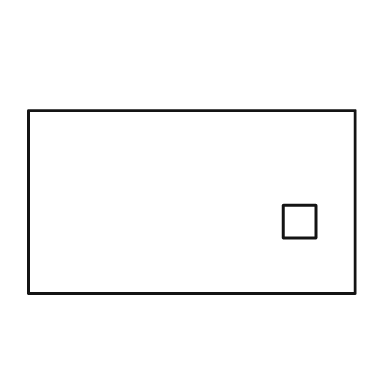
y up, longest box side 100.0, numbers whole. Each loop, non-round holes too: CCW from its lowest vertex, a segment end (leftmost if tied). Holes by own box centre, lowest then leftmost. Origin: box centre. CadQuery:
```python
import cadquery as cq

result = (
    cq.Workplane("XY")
    .moveTo(-50.0, -28.0)
    .lineTo(50.0, -28.0)
    .lineTo(50.0, 28.0)
    .lineTo(-50.0, 28.0)
    .close()
    .moveTo(28.0, -11.0)
    .lineTo(38.0, -11.0)
    .lineTo(38.0, -1.0)
    .lineTo(28.0, -1.0)
    .close()
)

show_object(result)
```